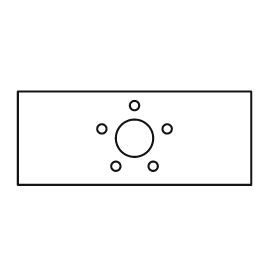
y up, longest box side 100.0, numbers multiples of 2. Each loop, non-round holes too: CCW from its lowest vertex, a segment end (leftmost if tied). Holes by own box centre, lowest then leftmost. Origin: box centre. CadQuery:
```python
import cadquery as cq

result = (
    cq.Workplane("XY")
    .moveTo(-50.0, -20.0)
    .lineTo(50.0, -20.0)
    .lineTo(50.0, 20.0)
    .lineTo(-50.0, 20.0)
    .close()
    .moveTo(-8.0, -12.0)
    .circle(2.0)
    .moveTo(8.0, -12.0)
    .circle(2.0)
    .moveTo(0.0, 0.0)
    .circle(8.0)
    .moveTo(-14.0, 4.0)
    .circle(2.0)
    .moveTo(14.0, 4.0)
    .circle(2.0)
    .moveTo(0.0, 14.0)
    .circle(2.0)
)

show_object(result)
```